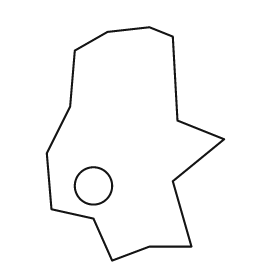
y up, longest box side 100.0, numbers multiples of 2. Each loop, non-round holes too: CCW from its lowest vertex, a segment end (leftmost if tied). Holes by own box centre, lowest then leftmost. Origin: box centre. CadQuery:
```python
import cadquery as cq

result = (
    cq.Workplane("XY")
    .moveTo(-10.0, -50.0)
    .lineTo(6.0, -44.0)
    .lineTo(24.0, -44.0)
    .lineTo(16.0, -16.0)
    .lineTo(38.0, 2.0)
    .lineTo(18.0, 10.0)
    .lineTo(16.0, 46.0)
    .lineTo(6.0, 50.0)
    .lineTo(-12.0, 48.0)
    .lineTo(-26.0, 40.0)
    .lineTo(-28.0, 16.0)
    .lineTo(-38.0, -4.0)
    .lineTo(-36.0, -28.0)
    .lineTo(-18.0, -32.0)
    .close()
    .moveTo(-18.0, -18.0)
    .circle(8.0)
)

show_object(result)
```